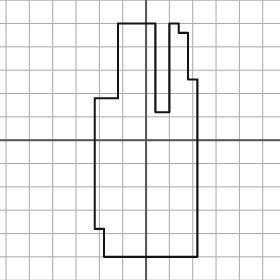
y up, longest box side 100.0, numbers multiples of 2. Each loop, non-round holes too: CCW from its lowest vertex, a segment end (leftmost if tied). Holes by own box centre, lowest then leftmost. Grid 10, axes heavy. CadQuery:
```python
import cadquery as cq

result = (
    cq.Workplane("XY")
    .moveTo(-18.0, -50.0)
    .lineTo(22.0, -50.0)
    .lineTo(22.0, 26.0)
    .lineTo(18.0, 26.0)
    .lineTo(18.0, 46.0)
    .lineTo(14.0, 46.0)
    .lineTo(14.0, 50.0)
    .lineTo(10.0, 50.0)
    .lineTo(10.0, 12.0)
    .lineTo(4.0, 12.0)
    .lineTo(4.0, 50.0)
    .lineTo(-12.0, 50.0)
    .lineTo(-12.0, 18.0)
    .lineTo(-22.0, 18.0)
    .lineTo(-22.0, -38.0)
    .lineTo(-18.0, -38.0)
    .close()
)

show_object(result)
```